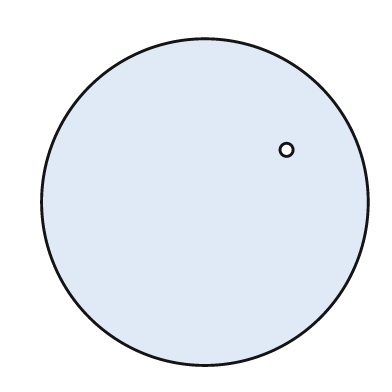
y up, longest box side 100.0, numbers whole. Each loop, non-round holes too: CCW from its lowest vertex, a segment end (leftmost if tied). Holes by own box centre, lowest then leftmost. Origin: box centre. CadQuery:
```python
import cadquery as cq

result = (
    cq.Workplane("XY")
    .moveTo(0.0, 0.0)
    .circle(50.0)
    .moveTo(25.0, 16.0)
    .circle(2.0)
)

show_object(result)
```